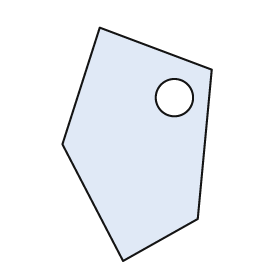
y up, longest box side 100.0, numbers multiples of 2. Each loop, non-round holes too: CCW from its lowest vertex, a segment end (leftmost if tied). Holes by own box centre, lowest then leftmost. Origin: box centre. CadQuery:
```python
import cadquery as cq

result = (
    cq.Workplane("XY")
    .moveTo(-6.0, -50.0)
    .lineTo(26.0, -32.0)
    .lineTo(32.0, 32.0)
    .lineTo(-16.0, 50.0)
    .lineTo(-32.0, 0.0)
    .close()
    .moveTo(16.0, 20.0)
    .circle(8.0)
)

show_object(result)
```